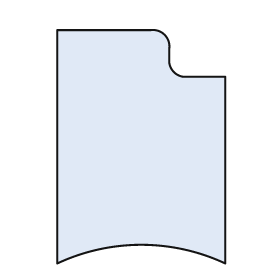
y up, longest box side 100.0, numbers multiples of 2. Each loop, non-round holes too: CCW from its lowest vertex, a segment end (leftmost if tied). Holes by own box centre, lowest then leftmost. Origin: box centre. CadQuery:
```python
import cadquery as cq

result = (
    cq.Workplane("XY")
    .moveTo(-36.0, -50.0)
    .threePointArc((0.0, -42.0), (36.0, -50.0))
    .lineTo(36.0, 30.0)
    .lineTo(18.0, 30.0)
    .threePointArc((14.0, 32.0), (12.0, 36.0))
    .lineTo(12.0, 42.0)
    .threePointArc((10.0, 48.0), (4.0, 50.0))
    .lineTo(-36.0, 50.0)
    .close()
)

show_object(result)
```